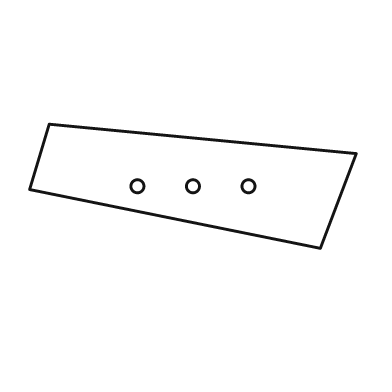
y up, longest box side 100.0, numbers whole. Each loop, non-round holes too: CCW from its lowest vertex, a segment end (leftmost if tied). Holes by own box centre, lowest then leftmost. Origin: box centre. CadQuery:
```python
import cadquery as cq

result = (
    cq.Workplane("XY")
    .moveTo(39.0, -19.0)
    .lineTo(50.0, 10.0)
    .lineTo(-44.0, 19.0)
    .lineTo(-50.0, -1.0)
    .close()
    .moveTo(-17.0, 0.0)
    .circle(2.0)
    .moveTo(0.0, 0.0)
    .circle(2.0)
    .moveTo(17.0, 0.0)
    .circle(2.0)
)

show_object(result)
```